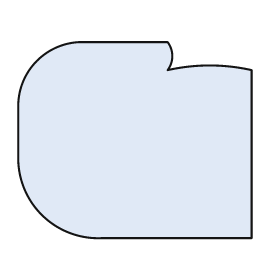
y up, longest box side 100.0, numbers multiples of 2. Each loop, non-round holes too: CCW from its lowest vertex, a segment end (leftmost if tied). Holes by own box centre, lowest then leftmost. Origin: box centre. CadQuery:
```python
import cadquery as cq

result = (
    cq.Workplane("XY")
    .moveTo(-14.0, -42.0)
    .lineTo(50.0, -42.0)
    .lineTo(50.0, 30.0)
    .threePointArc((32.0, 32.0), (14.0, 30.0))
    .threePointArc((16.0, 36.0), (14.0, 42.0))
    .lineTo(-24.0, 42.0)
    .threePointArc((-42.0, 34.0), (-50.0, 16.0))
    .lineTo(-50.0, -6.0)
    .threePointArc((-40.0, -32.0), (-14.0, -42.0))
    .close()
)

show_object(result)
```